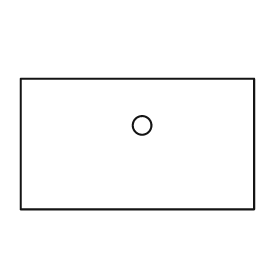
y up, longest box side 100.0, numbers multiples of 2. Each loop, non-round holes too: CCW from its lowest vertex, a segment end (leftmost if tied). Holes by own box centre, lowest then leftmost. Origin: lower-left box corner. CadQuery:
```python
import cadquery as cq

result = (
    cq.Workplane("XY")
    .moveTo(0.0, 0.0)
    .lineTo(100.0, 0.0)
    .lineTo(100.0, 56.0)
    .lineTo(0.0, 56.0)
    .close()
    .moveTo(52.0, 36.0)
    .circle(4.0)
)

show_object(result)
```